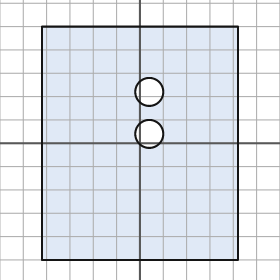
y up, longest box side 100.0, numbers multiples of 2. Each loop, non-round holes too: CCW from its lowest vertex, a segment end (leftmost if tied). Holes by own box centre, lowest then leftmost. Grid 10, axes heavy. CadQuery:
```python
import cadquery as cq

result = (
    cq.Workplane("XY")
    .moveTo(-42.0, -50.0)
    .lineTo(42.0, -50.0)
    .lineTo(42.0, 50.0)
    .lineTo(-42.0, 50.0)
    .close()
    .moveTo(4.0, 4.0)
    .circle(6.0)
    .moveTo(4.0, 22.0)
    .circle(6.0)
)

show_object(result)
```